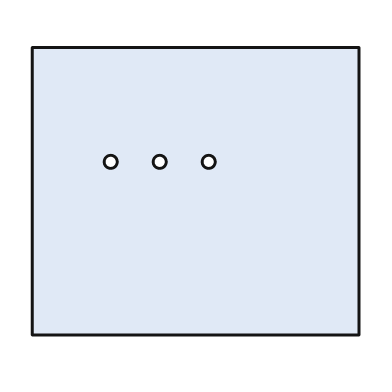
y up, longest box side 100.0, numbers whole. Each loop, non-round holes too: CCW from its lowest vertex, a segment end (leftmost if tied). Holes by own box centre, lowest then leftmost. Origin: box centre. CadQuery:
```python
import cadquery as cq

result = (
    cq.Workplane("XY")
    .moveTo(-50.0, -44.0)
    .lineTo(50.0, -44.0)
    .lineTo(50.0, 44.0)
    .lineTo(-50.0, 44.0)
    .close()
    .moveTo(-26.0, 9.0)
    .circle(2.0)
    .moveTo(-11.0, 9.0)
    .circle(2.0)
    .moveTo(4.0, 9.0)
    .circle(2.0)
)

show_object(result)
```